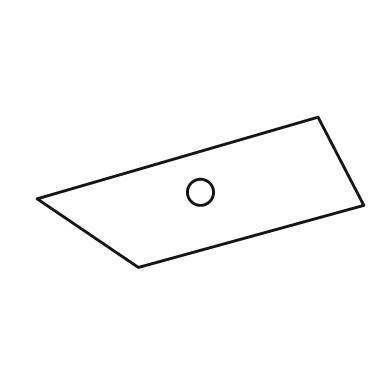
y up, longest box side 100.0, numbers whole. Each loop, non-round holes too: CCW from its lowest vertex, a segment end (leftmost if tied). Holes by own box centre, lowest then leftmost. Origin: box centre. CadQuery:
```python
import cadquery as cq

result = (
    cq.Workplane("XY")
    .moveTo(-19.0, -23.0)
    .lineTo(50.0, -4.0)
    .lineTo(36.0, 23.0)
    .lineTo(-50.0, -2.0)
    .close()
    .moveTo(0.0, 0.0)
    .circle(4.0)
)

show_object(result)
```